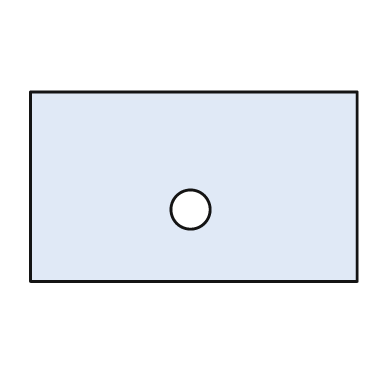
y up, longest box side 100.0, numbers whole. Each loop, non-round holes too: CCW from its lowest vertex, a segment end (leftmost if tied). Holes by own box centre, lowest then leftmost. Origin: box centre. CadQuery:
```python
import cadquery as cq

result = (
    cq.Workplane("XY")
    .moveTo(-50.0, -29.0)
    .lineTo(50.0, -29.0)
    .lineTo(50.0, 29.0)
    .lineTo(-50.0, 29.0)
    .close()
    .moveTo(-1.0, -7.0)
    .circle(6.0)
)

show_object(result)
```